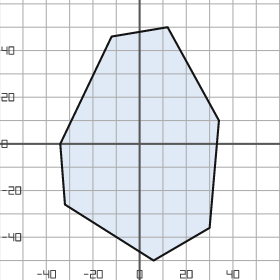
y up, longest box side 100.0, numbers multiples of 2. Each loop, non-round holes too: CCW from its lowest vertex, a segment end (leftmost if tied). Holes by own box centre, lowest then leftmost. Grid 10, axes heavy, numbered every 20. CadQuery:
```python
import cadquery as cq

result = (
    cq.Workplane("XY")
    .moveTo(6.0, -50.0)
    .lineTo(30.0, -36.0)
    .lineTo(34.0, 10.0)
    .lineTo(12.0, 50.0)
    .lineTo(-12.0, 46.0)
    .lineTo(-34.0, 0.0)
    .lineTo(-32.0, -26.0)
    .close()
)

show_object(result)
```